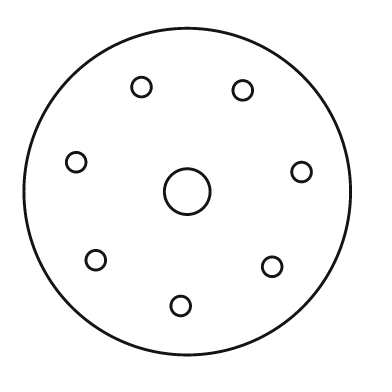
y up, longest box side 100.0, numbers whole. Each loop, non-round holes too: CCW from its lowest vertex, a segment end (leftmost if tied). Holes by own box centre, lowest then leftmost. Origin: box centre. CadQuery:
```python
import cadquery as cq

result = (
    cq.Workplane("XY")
    .moveTo(0.0, 0.0)
    .circle(50.0)
    .moveTo(-2.0, -35.0)
    .circle(3.0)
    .moveTo(26.0, -23.0)
    .circle(3.0)
    .moveTo(-28.0, -21.0)
    .circle(3.0)
    .moveTo(0.0, 0.0)
    .circle(7.0)
    .moveTo(35.0, 6.0)
    .circle(3.0)
    .moveTo(-34.0, 9.0)
    .circle(3.0)
    .moveTo(17.0, 31.0)
    .circle(3.0)
    .moveTo(-14.0, 32.0)
    .circle(3.0)
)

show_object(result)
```